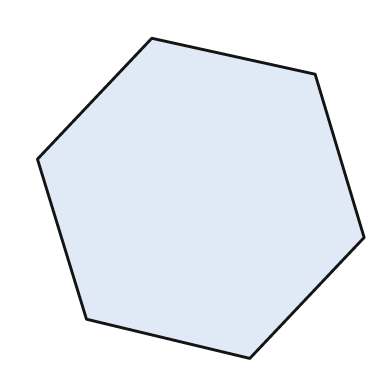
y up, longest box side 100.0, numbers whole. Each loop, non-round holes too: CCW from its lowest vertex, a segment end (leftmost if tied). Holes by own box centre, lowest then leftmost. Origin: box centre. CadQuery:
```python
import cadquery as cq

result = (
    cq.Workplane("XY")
    .moveTo(15.0, -49.0)
    .lineTo(50.0, -12.0)
    .lineTo(35.0, 38.0)
    .lineTo(-15.0, 49.0)
    .lineTo(-50.0, 12.0)
    .lineTo(-35.0, -37.0)
    .close()
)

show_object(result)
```